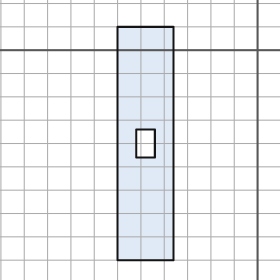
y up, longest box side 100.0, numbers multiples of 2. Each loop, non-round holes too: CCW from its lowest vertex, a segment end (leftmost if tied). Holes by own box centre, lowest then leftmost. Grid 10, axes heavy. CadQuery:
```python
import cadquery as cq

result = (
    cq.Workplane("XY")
    .moveTo(-60.0, -90.0)
    .lineTo(-36.0, -90.0)
    .lineTo(-36.0, 10.0)
    .lineTo(-60.0, 10.0)
    .close()
    .moveTo(-52.0, -46.0)
    .lineTo(-44.0, -46.0)
    .lineTo(-44.0, -34.0)
    .lineTo(-52.0, -34.0)
    .close()
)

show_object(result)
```